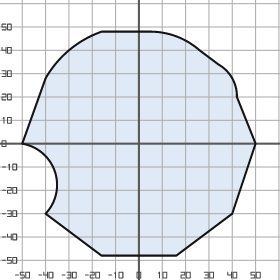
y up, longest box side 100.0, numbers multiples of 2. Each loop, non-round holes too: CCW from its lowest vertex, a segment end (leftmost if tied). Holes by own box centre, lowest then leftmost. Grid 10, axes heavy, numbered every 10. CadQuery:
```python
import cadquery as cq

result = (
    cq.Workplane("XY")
    .moveTo(-16.0, -48.0)
    .lineTo(16.0, -48.0)
    .lineTo(40.0, -30.0)
    .lineTo(50.0, 0.0)
    .lineTo(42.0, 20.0)
    .threePointArc((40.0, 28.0), (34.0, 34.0))
    .lineTo(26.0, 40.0)
    .threePointArc((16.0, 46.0), (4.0, 48.0))
    .lineTo(-16.0, 48.0)
    .threePointArc((-30.0, 40.0), (-40.0, 28.0))
    .lineTo(-50.0, 0.0)
    .threePointArc((-36.0, -12.0), (-40.0, -30.0))
    .close()
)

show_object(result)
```